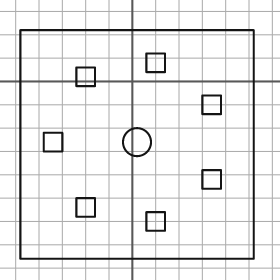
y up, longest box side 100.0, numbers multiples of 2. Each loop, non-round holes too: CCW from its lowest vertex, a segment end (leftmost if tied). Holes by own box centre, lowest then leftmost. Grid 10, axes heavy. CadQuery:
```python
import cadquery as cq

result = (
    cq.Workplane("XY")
    .moveTo(-48.0, -76.0)
    .lineTo(52.0, -76.0)
    .lineTo(52.0, 22.0)
    .lineTo(-48.0, 22.0)
    .close()
    .moveTo(6.0, -64.0)
    .lineTo(14.0, -64.0)
    .lineTo(14.0, -56.0)
    .lineTo(6.0, -56.0)
    .close()
    .moveTo(-24.0, -58.0)
    .lineTo(-16.0, -58.0)
    .lineTo(-16.0, -50.0)
    .lineTo(-24.0, -50.0)
    .close()
    .moveTo(30.0, -46.0)
    .lineTo(38.0, -46.0)
    .lineTo(38.0, -38.0)
    .lineTo(30.0, -38.0)
    .close()
    .moveTo(-38.0, -30.0)
    .lineTo(-30.0, -30.0)
    .lineTo(-30.0, -22.0)
    .lineTo(-38.0, -22.0)
    .close()
    .moveTo(2.0, -26.0)
    .circle(6.0)
    .moveTo(30.0, -14.0)
    .lineTo(38.0, -14.0)
    .lineTo(38.0, -6.0)
    .lineTo(30.0, -6.0)
    .close()
    .moveTo(-24.0, -2.0)
    .lineTo(-16.0, -2.0)
    .lineTo(-16.0, 6.0)
    .lineTo(-24.0, 6.0)
    .close()
    .moveTo(6.0, 4.0)
    .lineTo(14.0, 4.0)
    .lineTo(14.0, 12.0)
    .lineTo(6.0, 12.0)
    .close()
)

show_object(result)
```